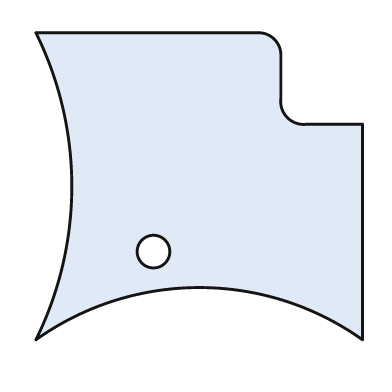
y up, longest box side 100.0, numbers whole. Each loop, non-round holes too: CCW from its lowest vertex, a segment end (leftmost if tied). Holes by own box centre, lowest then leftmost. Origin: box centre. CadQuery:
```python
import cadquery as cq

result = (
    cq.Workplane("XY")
    .moveTo(-50.0, -47.0)
    .threePointArc((0.0, -31.0), (50.0, -47.0))
    .lineTo(50.0, 19.0)
    .lineTo(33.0, 19.0)
    .threePointArc((27.0, 21.0), (25.0, 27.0))
    .lineTo(25.0, 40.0)
    .threePointArc((23.0, 45.0), (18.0, 47.0))
    .lineTo(-50.0, 47.0)
    .threePointArc((-39.0, 0.0), (-50.0, -47.0))
    .close()
    .moveTo(-14.0, -20.0)
    .circle(5.0)
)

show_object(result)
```